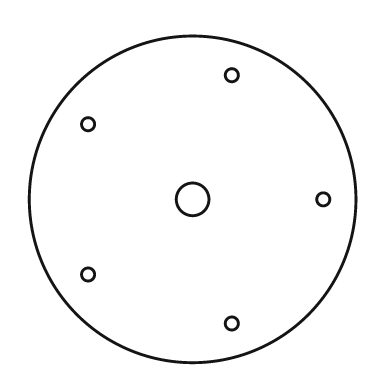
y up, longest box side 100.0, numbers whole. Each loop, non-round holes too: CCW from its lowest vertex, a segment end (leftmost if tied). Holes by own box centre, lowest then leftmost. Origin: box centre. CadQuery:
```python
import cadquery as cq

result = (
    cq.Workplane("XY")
    .moveTo(0.0, 0.0)
    .circle(50.0)
    .moveTo(12.0, -38.0)
    .circle(2.0)
    .moveTo(-32.0, -23.0)
    .circle(2.0)
    .moveTo(0.0, 0.0)
    .circle(5.0)
    .moveTo(40.0, 0.0)
    .circle(2.0)
    .moveTo(-32.0, 23.0)
    .circle(2.0)
    .moveTo(12.0, 38.0)
    .circle(2.0)
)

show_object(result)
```